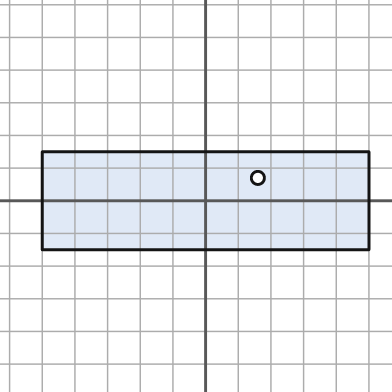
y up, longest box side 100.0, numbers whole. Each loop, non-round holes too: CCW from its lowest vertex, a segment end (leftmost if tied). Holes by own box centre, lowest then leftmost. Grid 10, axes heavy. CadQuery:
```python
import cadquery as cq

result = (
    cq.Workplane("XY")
    .moveTo(-50.0, -15.0)
    .lineTo(50.0, -15.0)
    .lineTo(50.0, 15.0)
    .lineTo(-50.0, 15.0)
    .close()
    .moveTo(16.0, 7.0)
    .circle(2.0)
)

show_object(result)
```